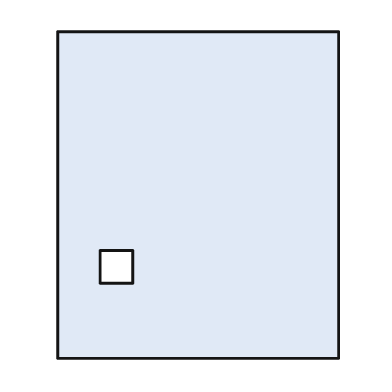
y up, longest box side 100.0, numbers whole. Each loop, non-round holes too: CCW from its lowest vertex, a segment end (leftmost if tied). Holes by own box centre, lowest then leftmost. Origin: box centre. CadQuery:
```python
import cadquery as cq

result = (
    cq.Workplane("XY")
    .moveTo(-43.0, -50.0)
    .lineTo(43.0, -50.0)
    .lineTo(43.0, 50.0)
    .lineTo(-43.0, 50.0)
    .close()
    .moveTo(-30.0, -27.0)
    .lineTo(-20.0, -27.0)
    .lineTo(-20.0, -17.0)
    .lineTo(-30.0, -17.0)
    .close()
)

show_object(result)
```